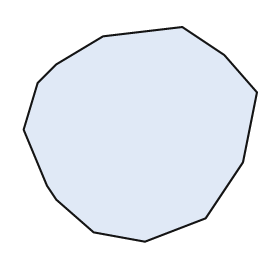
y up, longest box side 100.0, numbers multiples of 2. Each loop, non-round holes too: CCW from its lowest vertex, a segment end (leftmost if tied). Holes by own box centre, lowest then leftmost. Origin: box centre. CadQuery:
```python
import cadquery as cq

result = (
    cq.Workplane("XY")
    .moveTo(2.0, -46.0)
    .lineTo(28.0, -36.0)
    .lineTo(44.0, -12.0)
    .lineTo(50.0, 18.0)
    .lineTo(36.0, 34.0)
    .lineTo(18.0, 46.0)
    .lineTo(-16.0, 42.0)
    .lineTo(-36.0, 30.0)
    .lineTo(-44.0, 22.0)
    .lineTo(-50.0, 2.0)
    .lineTo(-40.0, -22.0)
    .lineTo(-36.0, -28.0)
    .lineTo(-20.0, -42.0)
    .close()
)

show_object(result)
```